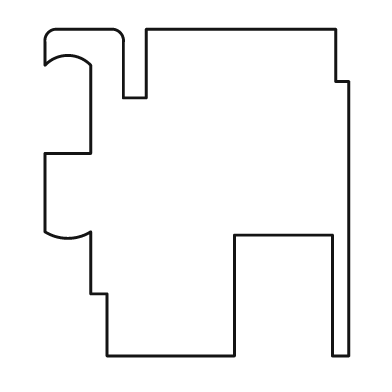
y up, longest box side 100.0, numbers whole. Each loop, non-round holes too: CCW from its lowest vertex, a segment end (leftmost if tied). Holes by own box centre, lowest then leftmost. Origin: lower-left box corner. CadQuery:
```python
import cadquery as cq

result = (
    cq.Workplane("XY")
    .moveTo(19.0, 0.0)
    .lineTo(58.0, 0.0)
    .lineTo(58.0, 37.0)
    .lineTo(88.0, 37.0)
    .lineTo(88.0, 0.0)
    .lineTo(93.0, 0.0)
    .lineTo(93.0, 84.0)
    .lineTo(89.0, 84.0)
    .lineTo(89.0, 100.0)
    .lineTo(31.0, 100.0)
    .lineTo(31.0, 79.0)
    .lineTo(24.0, 79.0)
    .lineTo(24.0, 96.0)
    .threePointArc((23.0, 99.0), (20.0, 100.0))
    .lineTo(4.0, 100.0)
    .threePointArc((1.0, 99.0), (0.0, 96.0))
    .lineTo(0.0, 89.0)
    .threePointArc((7.0, 92.0), (14.0, 89.0))
    .lineTo(14.0, 62.0)
    .lineTo(0.0, 62.0)
    .lineTo(0.0, 38.0)
    .threePointArc((7.0, 36.0), (14.0, 38.0))
    .lineTo(14.0, 19.0)
    .lineTo(19.0, 19.0)
    .close()
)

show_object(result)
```